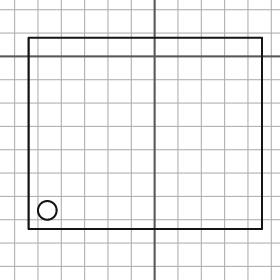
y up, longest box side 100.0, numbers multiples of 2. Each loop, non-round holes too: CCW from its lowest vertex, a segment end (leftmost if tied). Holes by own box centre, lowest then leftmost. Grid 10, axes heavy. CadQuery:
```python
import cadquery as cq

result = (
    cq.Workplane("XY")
    .moveTo(-54.0, -74.0)
    .lineTo(46.0, -74.0)
    .lineTo(46.0, 8.0)
    .lineTo(-54.0, 8.0)
    .close()
    .moveTo(-46.0, -66.0)
    .circle(4.0)
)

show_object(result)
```